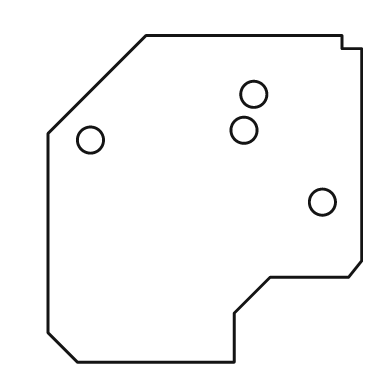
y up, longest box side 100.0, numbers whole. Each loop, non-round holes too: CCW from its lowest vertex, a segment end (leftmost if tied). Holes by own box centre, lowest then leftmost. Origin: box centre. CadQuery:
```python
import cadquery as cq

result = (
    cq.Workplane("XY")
    .moveTo(-39.0, -50.0)
    .lineTo(9.0, -50.0)
    .lineTo(9.0, -35.0)
    .lineTo(20.0, -24.0)
    .lineTo(44.0, -24.0)
    .lineTo(48.0, -19.0)
    .lineTo(48.0, 46.0)
    .lineTo(42.0, 46.0)
    .lineTo(42.0, 50.0)
    .lineTo(-18.0, 50.0)
    .lineTo(-48.0, 20.0)
    .lineTo(-48.0, -41.0)
    .close()
    .moveTo(36.0, -1.0)
    .circle(4.0)
    .moveTo(-35.0, 18.0)
    .circle(4.0)
    .moveTo(12.0, 21.0)
    .circle(4.0)
    .moveTo(15.0, 32.0)
    .circle(4.0)
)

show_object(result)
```